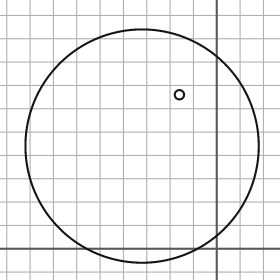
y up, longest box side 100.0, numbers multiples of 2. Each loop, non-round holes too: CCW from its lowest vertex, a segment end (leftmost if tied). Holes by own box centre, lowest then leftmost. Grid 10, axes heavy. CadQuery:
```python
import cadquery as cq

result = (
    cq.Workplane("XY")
    .moveTo(-32.0, 44.0)
    .circle(50.0)
    .moveTo(-16.0, 66.0)
    .circle(2.0)
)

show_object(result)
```